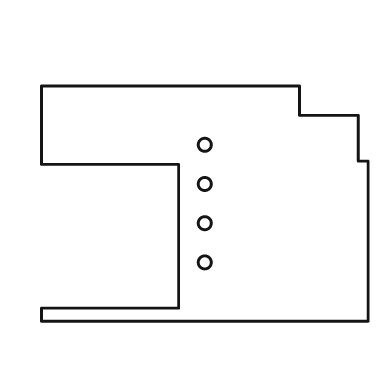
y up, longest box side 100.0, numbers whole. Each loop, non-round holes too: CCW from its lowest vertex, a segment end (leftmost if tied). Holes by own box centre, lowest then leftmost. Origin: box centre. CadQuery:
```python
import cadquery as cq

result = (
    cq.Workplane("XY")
    .moveTo(-50.0, -36.0)
    .lineTo(50.0, -36.0)
    .lineTo(50.0, 13.0)
    .lineTo(47.0, 13.0)
    .lineTo(47.0, 27.0)
    .lineTo(29.0, 27.0)
    .lineTo(29.0, 36.0)
    .lineTo(-50.0, 36.0)
    .lineTo(-50.0, 12.0)
    .lineTo(-8.0, 12.0)
    .lineTo(-8.0, -32.0)
    .lineTo(-50.0, -32.0)
    .close()
    .moveTo(0.0, -18.0)
    .circle(2.0)
    .moveTo(0.0, -6.0)
    .circle(2.0)
    .moveTo(0.0, 6.0)
    .circle(2.0)
    .moveTo(0.0, 18.0)
    .circle(2.0)
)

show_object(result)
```